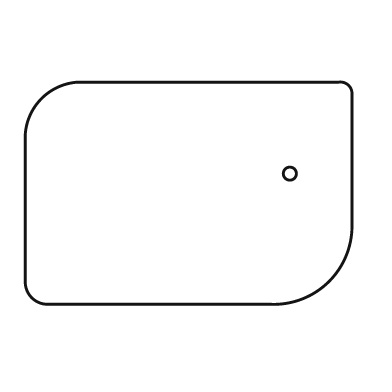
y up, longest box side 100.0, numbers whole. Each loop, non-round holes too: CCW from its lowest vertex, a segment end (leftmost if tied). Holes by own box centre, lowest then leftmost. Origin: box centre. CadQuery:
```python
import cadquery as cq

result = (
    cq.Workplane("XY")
    .moveTo(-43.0, -34.0)
    .lineTo(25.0, -34.0)
    .threePointArc((43.0, -27.0), (50.0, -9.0))
    .lineTo(50.0, 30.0)
    .threePointArc((49.0, 33.0), (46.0, 34.0))
    .lineTo(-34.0, 34.0)
    .threePointArc((-45.0, 29.0), (-50.0, 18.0))
    .lineTo(-50.0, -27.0)
    .threePointArc((-48.0, -32.0), (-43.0, -34.0))
    .close()
    .moveTo(31.0, 6.0)
    .circle(2.0)
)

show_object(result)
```